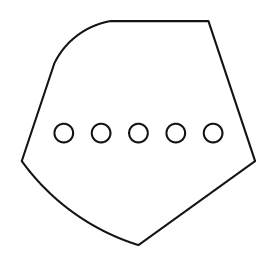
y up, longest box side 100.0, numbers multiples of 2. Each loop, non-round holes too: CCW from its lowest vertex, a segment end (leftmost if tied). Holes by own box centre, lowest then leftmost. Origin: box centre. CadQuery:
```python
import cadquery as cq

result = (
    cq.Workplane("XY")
    .moveTo(0.0, -48.0)
    .lineTo(50.0, -12.0)
    .lineTo(30.0, 48.0)
    .lineTo(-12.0, 48.0)
    .threePointArc((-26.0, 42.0), (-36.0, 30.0))
    .lineTo(-50.0, -12.0)
    .threePointArc((-28.0, -34.0), (0.0, -48.0))
    .close()
    .moveTo(-32.0, 0.0)
    .circle(4.0)
    .moveTo(-16.0, 0.0)
    .circle(4.0)
    .moveTo(0.0, 0.0)
    .circle(4.0)
    .moveTo(16.0, 0.0)
    .circle(4.0)
    .moveTo(32.0, 0.0)
    .circle(4.0)
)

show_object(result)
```